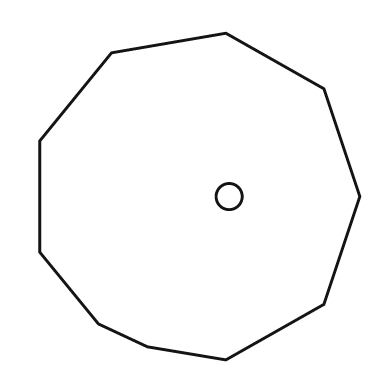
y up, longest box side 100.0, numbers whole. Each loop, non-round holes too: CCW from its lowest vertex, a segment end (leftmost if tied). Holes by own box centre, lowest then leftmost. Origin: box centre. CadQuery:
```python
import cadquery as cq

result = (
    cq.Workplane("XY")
    .moveTo(8.0, -50.0)
    .lineTo(38.0, -33.0)
    .lineTo(49.0, 0.0)
    .lineTo(38.0, 33.0)
    .lineTo(8.0, 50.0)
    .lineTo(-27.0, 44.0)
    .lineTo(-49.0, 17.0)
    .lineTo(-49.0, -17.0)
    .lineTo(-31.0, -39.0)
    .lineTo(-16.0, -46.0)
    .close()
    .moveTo(9.0, 0.0)
    .circle(4.0)
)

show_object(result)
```